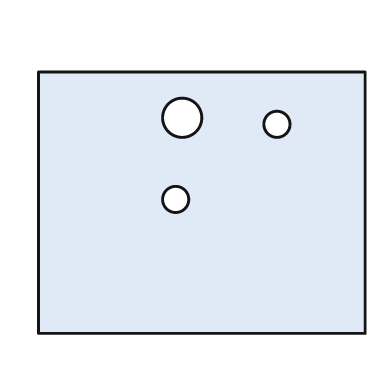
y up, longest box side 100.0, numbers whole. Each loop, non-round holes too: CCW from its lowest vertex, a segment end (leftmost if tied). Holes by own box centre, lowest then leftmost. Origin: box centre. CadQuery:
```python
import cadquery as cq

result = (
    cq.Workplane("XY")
    .moveTo(-50.0, -40.0)
    .lineTo(50.0, -40.0)
    .lineTo(50.0, 40.0)
    .lineTo(-50.0, 40.0)
    .close()
    .moveTo(-8.0, 1.0)
    .circle(4.0)
    .moveTo(23.0, 24.0)
    .circle(4.0)
    .moveTo(-6.0, 26.0)
    .circle(6.0)
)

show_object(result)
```